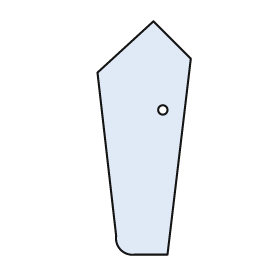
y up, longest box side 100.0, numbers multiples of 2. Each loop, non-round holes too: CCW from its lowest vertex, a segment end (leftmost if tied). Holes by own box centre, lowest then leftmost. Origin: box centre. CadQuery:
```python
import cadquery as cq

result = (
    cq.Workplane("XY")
    .moveTo(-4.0, -50.0)
    .lineTo(10.0, -50.0)
    .lineTo(20.0, 34.0)
    .lineTo(4.0, 50.0)
    .lineTo(-20.0, 28.0)
    .lineTo(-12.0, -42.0)
    .threePointArc((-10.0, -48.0), (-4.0, -50.0))
    .close()
    .moveTo(8.0, 12.0)
    .circle(2.0)
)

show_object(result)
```